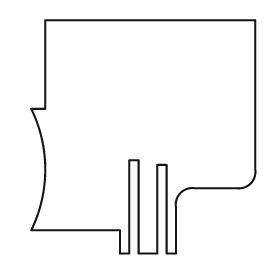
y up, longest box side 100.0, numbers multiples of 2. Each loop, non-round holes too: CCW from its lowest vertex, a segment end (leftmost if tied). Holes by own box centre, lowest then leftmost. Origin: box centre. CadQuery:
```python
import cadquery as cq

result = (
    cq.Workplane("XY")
    .moveTo(-10.0, -50.0)
    .lineTo(-6.0, -50.0)
    .lineTo(-6.0, -10.0)
    .lineTo(-2.0, -10.0)
    .lineTo(-2.0, -50.0)
    .lineTo(6.0, -50.0)
    .lineTo(6.0, -12.0)
    .lineTo(10.0, -12.0)
    .lineTo(10.0, -50.0)
    .lineTo(14.0, -50.0)
    .lineTo(14.0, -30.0)
    .threePointArc((16.0, -24.0), (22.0, -22.0))
    .lineTo(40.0, -22.0)
    .threePointArc((46.0, -20.0), (48.0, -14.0))
    .lineTo(48.0, 50.0)
    .lineTo(-42.0, 50.0)
    .lineTo(-42.0, 12.0)
    .lineTo(-48.0, 12.0)
    .threePointArc((-42.0, -14.0), (-48.0, -40.0))
    .lineTo(-10.0, -40.0)
    .close()
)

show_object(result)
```